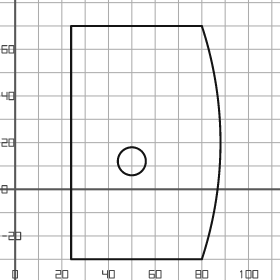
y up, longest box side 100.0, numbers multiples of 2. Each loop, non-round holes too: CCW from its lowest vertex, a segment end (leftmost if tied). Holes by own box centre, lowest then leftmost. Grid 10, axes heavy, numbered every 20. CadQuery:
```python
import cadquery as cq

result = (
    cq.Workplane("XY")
    .moveTo(24.0, -30.0)
    .lineTo(80.0, -30.0)
    .threePointArc((88.0, 20.0), (80.0, 70.0))
    .lineTo(24.0, 70.0)
    .close()
    .moveTo(50.0, 12.0)
    .circle(6.0)
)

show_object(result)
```